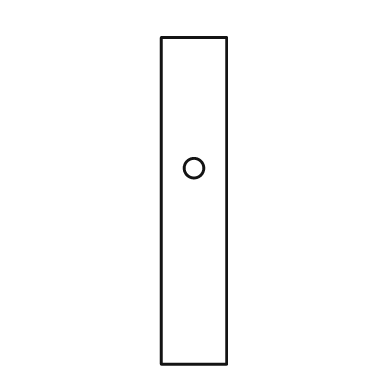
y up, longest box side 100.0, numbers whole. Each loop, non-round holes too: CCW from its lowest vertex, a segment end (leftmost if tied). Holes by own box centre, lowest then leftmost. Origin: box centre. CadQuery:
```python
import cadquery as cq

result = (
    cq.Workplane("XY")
    .moveTo(-10.0, -50.0)
    .lineTo(10.0, -50.0)
    .lineTo(10.0, 50.0)
    .lineTo(-10.0, 50.0)
    .close()
    .moveTo(0.0, 10.0)
    .circle(3.0)
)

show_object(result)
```